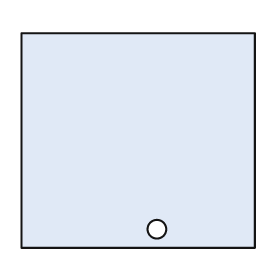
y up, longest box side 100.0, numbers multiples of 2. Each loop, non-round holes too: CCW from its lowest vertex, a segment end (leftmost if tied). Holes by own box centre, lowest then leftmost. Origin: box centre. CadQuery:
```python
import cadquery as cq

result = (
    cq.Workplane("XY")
    .moveTo(-50.0, -46.0)
    .lineTo(50.0, -46.0)
    .lineTo(50.0, 46.0)
    .lineTo(-50.0, 46.0)
    .close()
    .moveTo(8.0, -38.0)
    .circle(4.0)
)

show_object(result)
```